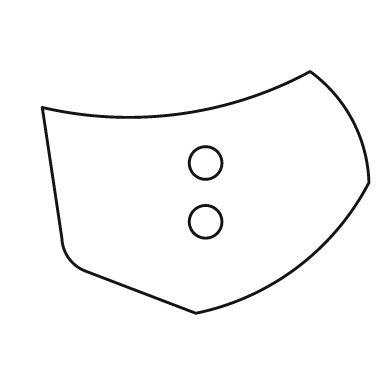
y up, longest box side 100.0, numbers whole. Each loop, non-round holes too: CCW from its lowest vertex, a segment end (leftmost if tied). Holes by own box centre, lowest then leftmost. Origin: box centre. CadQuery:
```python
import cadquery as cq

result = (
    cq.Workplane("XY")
    .moveTo(-3.0, -37.0)
    .threePointArc((28.0, -23.0), (50.0, 3.0))
    .threePointArc((45.0, 22.0), (32.0, 37.0))
    .threePointArc((-8.0, 24.0), (-50.0, 26.0))
    .lineTo(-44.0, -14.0)
    .threePointArc((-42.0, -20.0), (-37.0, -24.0))
    .close()
    .moveTo(0.0, -9.0)
    .circle(5.0)
    .moveTo(0.0, 9.0)
    .circle(5.0)
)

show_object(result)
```